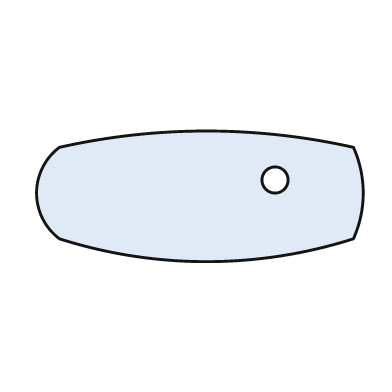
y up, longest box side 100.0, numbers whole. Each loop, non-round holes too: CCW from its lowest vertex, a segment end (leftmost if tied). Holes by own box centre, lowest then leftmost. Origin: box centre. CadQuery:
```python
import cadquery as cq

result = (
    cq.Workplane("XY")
    .moveTo(-43.0, -13.0)
    .threePointArc((2.0, -20.0), (47.0, -13.0))
    .threePointArc((50.0, 1.0), (47.0, 15.0))
    .threePointArc((2.0, 20.0), (-43.0, 15.0))
    .threePointArc((-50.0, 1.0), (-43.0, -13.0))
    .close()
    .moveTo(23.0, 5.0)
    .circle(4.0)
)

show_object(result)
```